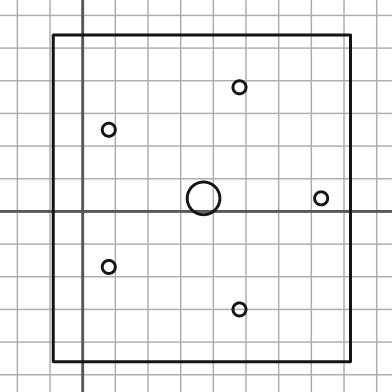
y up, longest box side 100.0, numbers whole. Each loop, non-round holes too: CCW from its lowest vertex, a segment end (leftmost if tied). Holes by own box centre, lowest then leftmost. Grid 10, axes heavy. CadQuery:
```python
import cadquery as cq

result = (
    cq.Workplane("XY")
    .moveTo(-9.0, -46.0)
    .lineTo(82.0, -46.0)
    .lineTo(82.0, 54.0)
    .lineTo(-9.0, 54.0)
    .close()
    .moveTo(48.0, -30.0)
    .circle(2.0)
    .moveTo(8.0, -17.0)
    .circle(2.0)
    .moveTo(37.0, 4.0)
    .circle(5.0)
    .moveTo(73.0, 4.0)
    .circle(2.0)
    .moveTo(8.0, 25.0)
    .circle(2.0)
    .moveTo(48.0, 38.0)
    .circle(2.0)
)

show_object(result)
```